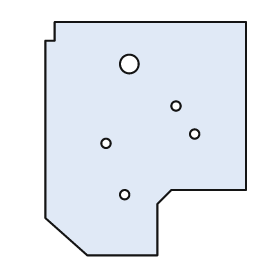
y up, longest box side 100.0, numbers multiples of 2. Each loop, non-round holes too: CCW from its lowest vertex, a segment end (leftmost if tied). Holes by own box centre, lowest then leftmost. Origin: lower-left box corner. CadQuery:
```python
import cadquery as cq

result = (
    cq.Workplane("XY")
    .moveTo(18.0, 0.0)
    .lineTo(48.0, 0.0)
    .lineTo(48.0, 22.0)
    .lineTo(54.0, 28.0)
    .lineTo(86.0, 28.0)
    .lineTo(86.0, 100.0)
    .lineTo(4.0, 100.0)
    .lineTo(4.0, 92.0)
    .lineTo(0.0, 92.0)
    .lineTo(0.0, 16.0)
    .close()
    .moveTo(34.0, 26.0)
    .circle(2.0)
    .moveTo(26.0, 48.0)
    .circle(2.0)
    .moveTo(64.0, 52.0)
    .circle(2.0)
    .moveTo(56.0, 64.0)
    .circle(2.0)
    .moveTo(36.0, 82.0)
    .circle(4.0)
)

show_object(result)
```